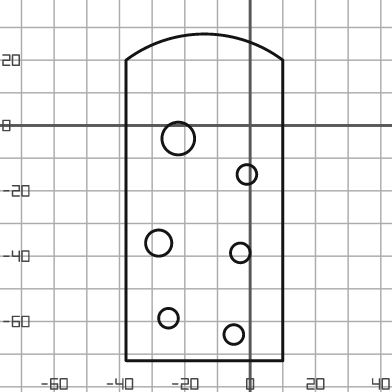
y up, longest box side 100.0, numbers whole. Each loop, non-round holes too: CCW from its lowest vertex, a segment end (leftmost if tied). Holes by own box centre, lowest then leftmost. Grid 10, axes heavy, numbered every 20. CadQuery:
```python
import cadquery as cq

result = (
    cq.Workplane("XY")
    .moveTo(-38.0, -72.0)
    .lineTo(10.0, -72.0)
    .lineTo(10.0, 20.0)
    .threePointArc((-14.0, 28.0), (-38.0, 20.0))
    .close()
    .moveTo(-5.0, -64.0)
    .circle(3.0)
    .moveTo(-25.0, -59.0)
    .circle(3.0)
    .moveTo(-3.0, -39.0)
    .circle(3.0)
    .moveTo(-28.0, -36.0)
    .circle(4.0)
    .moveTo(-1.0, -15.0)
    .circle(3.0)
    .moveTo(-22.0, -4.0)
    .circle(5.0)
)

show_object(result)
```